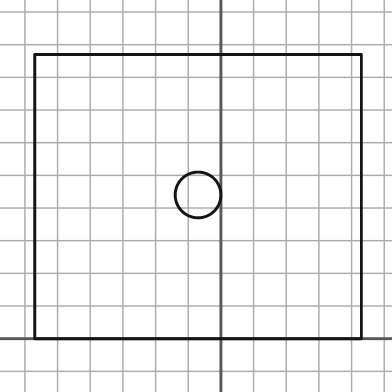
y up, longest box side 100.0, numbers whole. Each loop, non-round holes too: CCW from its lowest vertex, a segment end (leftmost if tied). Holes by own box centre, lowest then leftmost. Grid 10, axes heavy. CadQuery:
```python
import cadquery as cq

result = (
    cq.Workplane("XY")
    .moveTo(-57.0, 0.0)
    .lineTo(43.0, 0.0)
    .lineTo(43.0, 87.0)
    .lineTo(-57.0, 87.0)
    .close()
    .moveTo(-7.0, 44.0)
    .circle(7.0)
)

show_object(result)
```